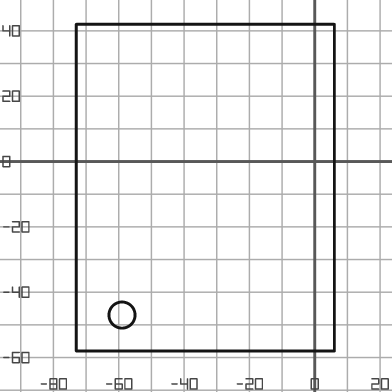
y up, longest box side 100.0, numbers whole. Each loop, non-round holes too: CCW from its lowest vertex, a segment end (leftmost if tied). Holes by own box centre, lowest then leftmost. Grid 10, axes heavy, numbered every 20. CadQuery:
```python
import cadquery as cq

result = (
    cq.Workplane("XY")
    .moveTo(-73.0, -58.0)
    .lineTo(6.0, -58.0)
    .lineTo(6.0, 42.0)
    .lineTo(-73.0, 42.0)
    .close()
    .moveTo(-59.0, -47.0)
    .circle(4.0)
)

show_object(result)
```